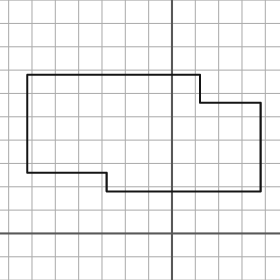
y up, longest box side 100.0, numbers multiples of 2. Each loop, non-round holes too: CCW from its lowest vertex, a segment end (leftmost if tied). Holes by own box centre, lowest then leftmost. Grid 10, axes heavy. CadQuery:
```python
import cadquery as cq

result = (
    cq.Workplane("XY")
    .moveTo(-28.0, 18.0)
    .lineTo(38.0, 18.0)
    .lineTo(38.0, 56.0)
    .lineTo(12.0, 56.0)
    .lineTo(12.0, 68.0)
    .lineTo(-62.0, 68.0)
    .lineTo(-62.0, 26.0)
    .lineTo(-28.0, 26.0)
    .close()
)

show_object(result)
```